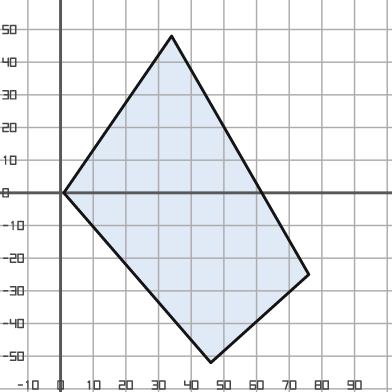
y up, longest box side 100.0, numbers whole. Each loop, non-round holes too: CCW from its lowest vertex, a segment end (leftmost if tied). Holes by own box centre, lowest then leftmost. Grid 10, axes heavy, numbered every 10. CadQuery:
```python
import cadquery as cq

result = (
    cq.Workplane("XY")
    .moveTo(46.0, -52.0)
    .lineTo(76.0, -25.0)
    .lineTo(34.0, 48.0)
    .lineTo(1.0, 0.0)
    .close()
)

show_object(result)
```